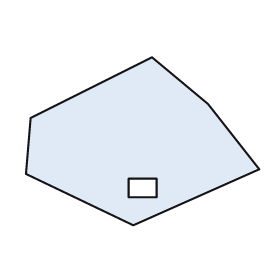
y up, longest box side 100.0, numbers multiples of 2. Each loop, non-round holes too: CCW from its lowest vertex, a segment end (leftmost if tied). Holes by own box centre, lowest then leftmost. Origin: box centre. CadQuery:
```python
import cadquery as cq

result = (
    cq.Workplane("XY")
    .moveTo(-4.0, -36.0)
    .lineTo(50.0, -12.0)
    .lineTo(28.0, 16.0)
    .lineTo(4.0, 36.0)
    .lineTo(-48.0, 10.0)
    .lineTo(-50.0, -14.0)
    .close()
    .moveTo(-6.0, -24.0)
    .lineTo(6.0, -24.0)
    .lineTo(6.0, -16.0)
    .lineTo(-6.0, -16.0)
    .close()
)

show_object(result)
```